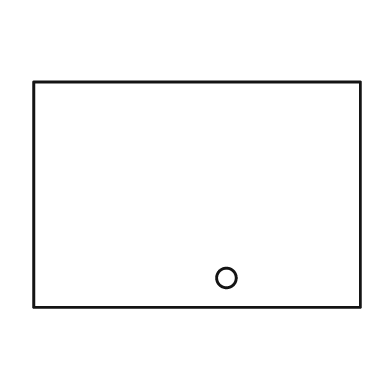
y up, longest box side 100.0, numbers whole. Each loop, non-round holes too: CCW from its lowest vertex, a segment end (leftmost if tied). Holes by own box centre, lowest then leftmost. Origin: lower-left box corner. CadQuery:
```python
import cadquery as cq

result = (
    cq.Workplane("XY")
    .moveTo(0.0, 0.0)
    .lineTo(100.0, 0.0)
    .lineTo(100.0, 69.0)
    .lineTo(0.0, 69.0)
    .close()
    .moveTo(59.0, 9.0)
    .circle(3.0)
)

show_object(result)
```